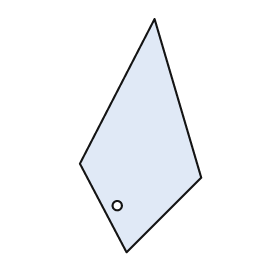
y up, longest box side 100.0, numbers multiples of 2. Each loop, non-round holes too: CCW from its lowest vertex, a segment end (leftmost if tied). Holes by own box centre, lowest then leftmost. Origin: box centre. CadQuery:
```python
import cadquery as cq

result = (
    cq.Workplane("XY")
    .moveTo(-6.0, -50.0)
    .lineTo(26.0, -18.0)
    .lineTo(6.0, 50.0)
    .lineTo(-26.0, -12.0)
    .close()
    .moveTo(-10.0, -30.0)
    .circle(2.0)
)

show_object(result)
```